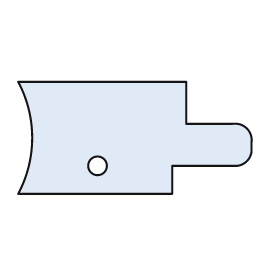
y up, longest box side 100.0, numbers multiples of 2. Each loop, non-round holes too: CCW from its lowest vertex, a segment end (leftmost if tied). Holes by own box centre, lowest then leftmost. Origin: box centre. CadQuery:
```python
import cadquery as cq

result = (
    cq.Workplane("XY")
    .moveTo(-50.0, -24.0)
    .lineTo(16.0, -24.0)
    .lineTo(16.0, -12.0)
    .lineTo(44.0, -12.0)
    .threePointArc((48.0, -10.0), (50.0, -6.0))
    .lineTo(50.0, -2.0)
    .threePointArc((48.0, 4.0), (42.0, 6.0))
    .lineTo(22.0, 6.0)
    .lineTo(22.0, 24.0)
    .lineTo(-50.0, 24.0)
    .threePointArc((-44.0, 0.0), (-50.0, -24.0))
    .close()
    .moveTo(-16.0, -12.0)
    .circle(4.0)
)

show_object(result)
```